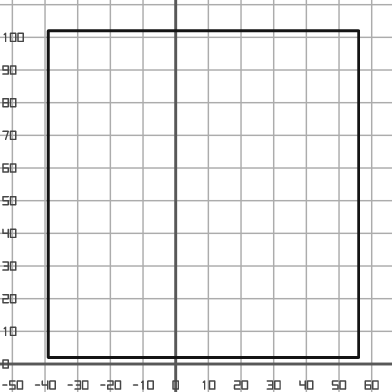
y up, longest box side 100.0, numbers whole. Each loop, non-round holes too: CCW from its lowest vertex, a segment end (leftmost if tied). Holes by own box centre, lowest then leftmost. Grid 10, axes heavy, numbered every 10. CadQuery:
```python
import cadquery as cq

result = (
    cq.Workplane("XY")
    .moveTo(-39.0, 2.0)
    .lineTo(56.0, 2.0)
    .lineTo(56.0, 102.0)
    .lineTo(-39.0, 102.0)
    .close()
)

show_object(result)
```